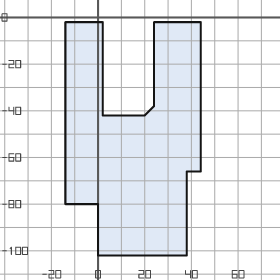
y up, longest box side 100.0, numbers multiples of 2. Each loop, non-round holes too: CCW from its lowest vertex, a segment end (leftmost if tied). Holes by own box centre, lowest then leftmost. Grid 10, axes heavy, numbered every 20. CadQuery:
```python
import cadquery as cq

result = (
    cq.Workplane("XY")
    .moveTo(0.0, -102.0)
    .lineTo(38.0, -102.0)
    .lineTo(38.0, -66.0)
    .lineTo(44.0, -66.0)
    .lineTo(44.0, -2.0)
    .lineTo(24.0, -2.0)
    .lineTo(24.0, -38.0)
    .lineTo(20.0, -42.0)
    .lineTo(2.0, -42.0)
    .lineTo(2.0, -2.0)
    .lineTo(-14.0, -2.0)
    .lineTo(-14.0, -80.0)
    .lineTo(0.0, -80.0)
    .close()
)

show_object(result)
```